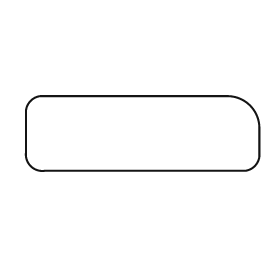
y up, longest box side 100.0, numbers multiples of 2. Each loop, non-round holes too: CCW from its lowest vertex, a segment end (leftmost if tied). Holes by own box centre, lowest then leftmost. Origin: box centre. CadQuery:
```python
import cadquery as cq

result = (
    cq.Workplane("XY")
    .moveTo(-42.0, -16.0)
    .lineTo(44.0, -16.0)
    .threePointArc((48.0, -14.0), (50.0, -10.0))
    .lineTo(50.0, 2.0)
    .threePointArc((46.0, 12.0), (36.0, 16.0))
    .lineTo(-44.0, 16.0)
    .threePointArc((-48.0, 14.0), (-50.0, 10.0))
    .lineTo(-50.0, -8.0)
    .threePointArc((-48.0, -14.0), (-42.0, -16.0))
    .close()
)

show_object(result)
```